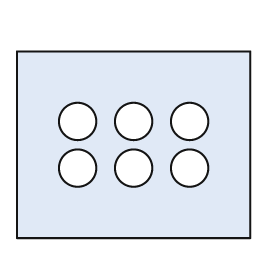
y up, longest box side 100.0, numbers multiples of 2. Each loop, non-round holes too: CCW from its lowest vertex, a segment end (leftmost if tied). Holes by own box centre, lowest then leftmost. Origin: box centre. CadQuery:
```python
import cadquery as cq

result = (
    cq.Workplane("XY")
    .moveTo(-50.0, -40.0)
    .lineTo(50.0, -40.0)
    .lineTo(50.0, 40.0)
    .lineTo(-50.0, 40.0)
    .close()
    .moveTo(-24.0, -10.0)
    .circle(8.0)
    .moveTo(0.0, -10.0)
    .circle(8.0)
    .moveTo(24.0, -10.0)
    .circle(8.0)
    .moveTo(-24.0, 10.0)
    .circle(8.0)
    .moveTo(0.0, 10.0)
    .circle(8.0)
    .moveTo(24.0, 10.0)
    .circle(8.0)
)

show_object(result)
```